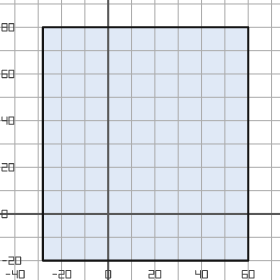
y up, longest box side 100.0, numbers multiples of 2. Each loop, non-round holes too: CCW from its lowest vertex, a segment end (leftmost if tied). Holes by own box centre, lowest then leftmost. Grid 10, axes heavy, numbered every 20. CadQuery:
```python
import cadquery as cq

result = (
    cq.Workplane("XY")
    .moveTo(-28.0, -20.0)
    .lineTo(60.0, -20.0)
    .lineTo(60.0, 80.0)
    .lineTo(-28.0, 80.0)
    .close()
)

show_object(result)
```